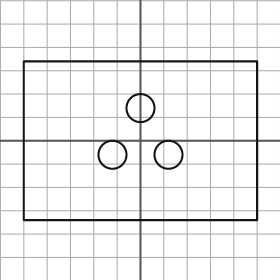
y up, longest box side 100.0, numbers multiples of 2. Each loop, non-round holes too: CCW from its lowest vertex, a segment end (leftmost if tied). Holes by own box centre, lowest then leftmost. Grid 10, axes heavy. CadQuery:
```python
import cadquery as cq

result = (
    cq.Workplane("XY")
    .moveTo(-50.0, -34.0)
    .lineTo(50.0, -34.0)
    .lineTo(50.0, 34.0)
    .lineTo(-50.0, 34.0)
    .close()
    .moveTo(-12.0, -6.0)
    .circle(6.0)
    .moveTo(12.0, -6.0)
    .circle(6.0)
    .moveTo(0.0, 14.0)
    .circle(6.0)
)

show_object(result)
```